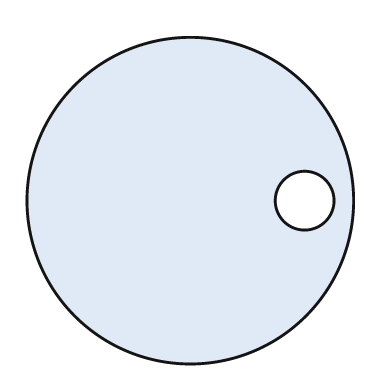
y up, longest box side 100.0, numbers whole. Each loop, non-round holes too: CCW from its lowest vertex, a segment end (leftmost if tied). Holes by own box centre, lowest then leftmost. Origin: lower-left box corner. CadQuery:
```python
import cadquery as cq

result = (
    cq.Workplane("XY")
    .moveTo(50.0, 50.0)
    .circle(50.0)
    .moveTo(85.0, 50.0)
    .circle(9.0)
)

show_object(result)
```